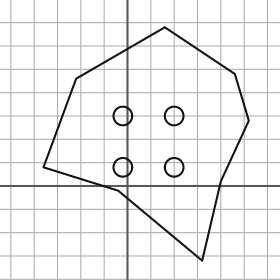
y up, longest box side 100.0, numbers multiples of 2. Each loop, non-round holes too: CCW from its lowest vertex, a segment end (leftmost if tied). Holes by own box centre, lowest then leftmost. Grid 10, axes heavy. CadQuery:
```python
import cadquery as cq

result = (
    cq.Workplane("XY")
    .moveTo(32.0, -32.0)
    .lineTo(40.0, 2.0)
    .lineTo(52.0, 28.0)
    .lineTo(46.0, 48.0)
    .lineTo(16.0, 68.0)
    .lineTo(-22.0, 46.0)
    .lineTo(-36.0, 8.0)
    .lineTo(-4.0, -2.0)
    .close()
    .moveTo(-2.0, 8.0)
    .circle(4.0)
    .moveTo(20.0, 8.0)
    .circle(4.0)
    .moveTo(-2.0, 30.0)
    .circle(4.0)
    .moveTo(20.0, 30.0)
    .circle(4.0)
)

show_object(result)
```